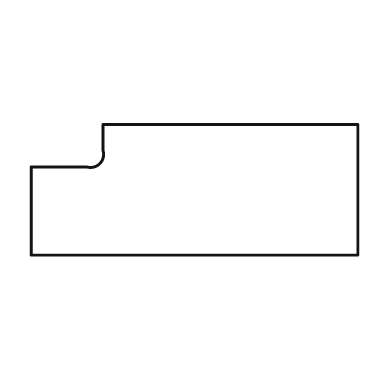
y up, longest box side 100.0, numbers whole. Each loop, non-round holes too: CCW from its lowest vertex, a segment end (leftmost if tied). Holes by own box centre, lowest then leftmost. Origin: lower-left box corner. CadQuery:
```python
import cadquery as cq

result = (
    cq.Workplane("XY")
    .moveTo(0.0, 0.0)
    .lineTo(100.0, 0.0)
    .lineTo(100.0, 40.0)
    .lineTo(22.0, 40.0)
    .lineTo(22.0, 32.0)
    .threePointArc((21.0, 28.0), (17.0, 27.0))
    .lineTo(0.0, 27.0)
    .close()
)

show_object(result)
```